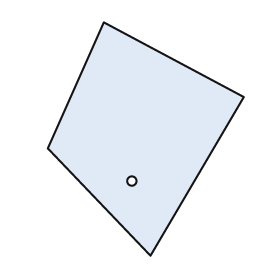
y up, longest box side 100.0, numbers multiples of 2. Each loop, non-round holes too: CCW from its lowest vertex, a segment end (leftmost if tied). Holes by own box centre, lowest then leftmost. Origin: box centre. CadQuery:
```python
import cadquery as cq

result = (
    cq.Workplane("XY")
    .moveTo(2.0, -50.0)
    .lineTo(42.0, 18.0)
    .lineTo(-18.0, 50.0)
    .lineTo(-42.0, -4.0)
    .close()
    .moveTo(-6.0, -18.0)
    .circle(2.0)
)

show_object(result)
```